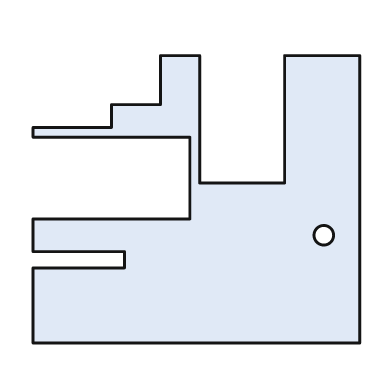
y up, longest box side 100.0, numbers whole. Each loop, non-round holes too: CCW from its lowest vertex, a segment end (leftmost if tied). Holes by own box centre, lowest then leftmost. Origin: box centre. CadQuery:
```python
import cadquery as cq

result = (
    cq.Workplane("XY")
    .moveTo(-50.0, -44.0)
    .lineTo(50.0, -44.0)
    .lineTo(50.0, 44.0)
    .lineTo(27.0, 44.0)
    .lineTo(27.0, 5.0)
    .lineTo(1.0, 5.0)
    .lineTo(1.0, 44.0)
    .lineTo(-11.0, 44.0)
    .lineTo(-11.0, 29.0)
    .lineTo(-26.0, 29.0)
    .lineTo(-26.0, 22.0)
    .lineTo(-50.0, 22.0)
    .lineTo(-50.0, 19.0)
    .lineTo(-2.0, 19.0)
    .lineTo(-2.0, -6.0)
    .lineTo(-50.0, -6.0)
    .lineTo(-50.0, -16.0)
    .lineTo(-22.0, -16.0)
    .lineTo(-22.0, -21.0)
    .lineTo(-50.0, -21.0)
    .close()
    .moveTo(39.0, -11.0)
    .circle(3.0)
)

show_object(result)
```